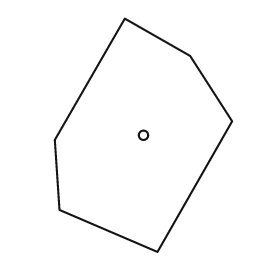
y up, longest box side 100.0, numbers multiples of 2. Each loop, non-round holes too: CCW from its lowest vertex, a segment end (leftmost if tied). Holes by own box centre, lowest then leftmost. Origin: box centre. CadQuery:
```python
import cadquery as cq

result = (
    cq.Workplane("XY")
    .moveTo(6.0, -50.0)
    .lineTo(38.0, 6.0)
    .lineTo(20.0, 34.0)
    .lineTo(-8.0, 50.0)
    .lineTo(-38.0, -2.0)
    .lineTo(-36.0, -32.0)
    .close()
    .moveTo(0.0, 0.0)
    .circle(2.0)
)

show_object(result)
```